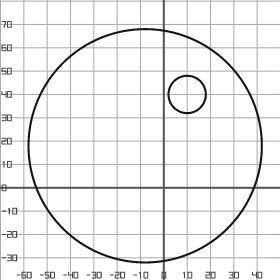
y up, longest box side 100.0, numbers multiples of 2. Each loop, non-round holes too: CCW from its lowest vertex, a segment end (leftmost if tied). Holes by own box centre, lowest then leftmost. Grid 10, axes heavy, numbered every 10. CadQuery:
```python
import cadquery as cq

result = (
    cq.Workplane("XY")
    .moveTo(-8.0, 18.0)
    .circle(50.0)
    .moveTo(10.0, 40.0)
    .circle(8.0)
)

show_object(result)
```